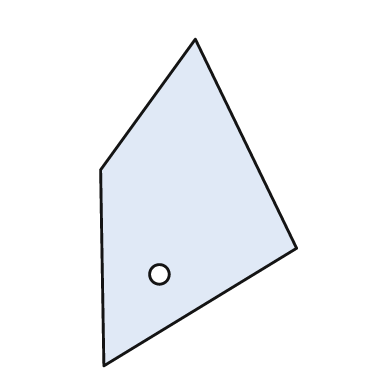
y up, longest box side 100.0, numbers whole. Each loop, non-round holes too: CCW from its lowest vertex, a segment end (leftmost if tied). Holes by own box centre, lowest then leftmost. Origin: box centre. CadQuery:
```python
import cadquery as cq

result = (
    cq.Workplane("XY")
    .moveTo(-29.0, -50.0)
    .lineTo(30.0, -14.0)
    .lineTo(-1.0, 50.0)
    .lineTo(-30.0, 10.0)
    .close()
    .moveTo(-12.0, -22.0)
    .circle(3.0)
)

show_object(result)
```